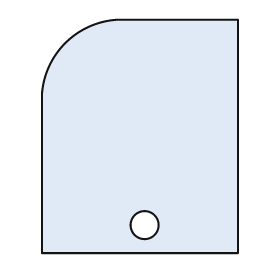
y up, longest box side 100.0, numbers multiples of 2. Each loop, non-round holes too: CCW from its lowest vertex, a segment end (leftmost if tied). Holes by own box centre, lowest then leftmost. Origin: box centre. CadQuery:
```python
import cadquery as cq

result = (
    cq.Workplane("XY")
    .moveTo(-42.0, -50.0)
    .lineTo(42.0, -50.0)
    .lineTo(42.0, 50.0)
    .lineTo(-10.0, 50.0)
    .threePointArc((-32.0, 40.0), (-42.0, 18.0))
    .close()
    .moveTo(2.0, -38.0)
    .circle(6.0)
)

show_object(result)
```